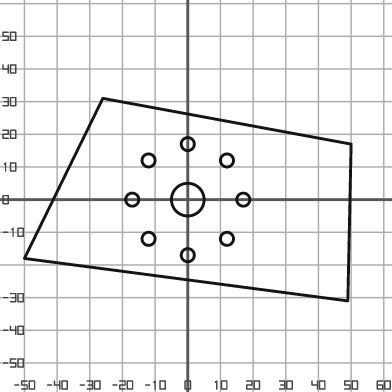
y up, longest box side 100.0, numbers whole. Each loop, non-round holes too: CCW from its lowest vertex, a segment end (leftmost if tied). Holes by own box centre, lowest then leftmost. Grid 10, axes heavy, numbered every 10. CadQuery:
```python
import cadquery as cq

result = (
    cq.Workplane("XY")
    .moveTo(49.0, -31.0)
    .lineTo(50.0, 17.0)
    .lineTo(-26.0, 31.0)
    .lineTo(-50.0, -18.0)
    .close()
    .moveTo(0.0, -17.0)
    .circle(2.0)
    .moveTo(-12.0, -12.0)
    .circle(2.0)
    .moveTo(12.0, -12.0)
    .circle(2.0)
    .moveTo(-17.0, 0.0)
    .circle(2.0)
    .moveTo(0.0, 0.0)
    .circle(5.0)
    .moveTo(17.0, 0.0)
    .circle(2.0)
    .moveTo(-12.0, 12.0)
    .circle(2.0)
    .moveTo(12.0, 12.0)
    .circle(2.0)
    .moveTo(0.0, 17.0)
    .circle(2.0)
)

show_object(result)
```